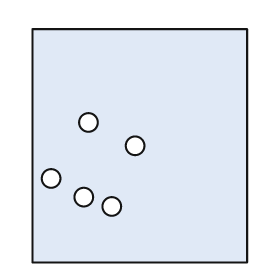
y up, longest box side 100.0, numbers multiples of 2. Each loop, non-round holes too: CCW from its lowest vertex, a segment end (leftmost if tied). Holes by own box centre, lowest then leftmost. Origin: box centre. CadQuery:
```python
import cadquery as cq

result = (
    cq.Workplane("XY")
    .moveTo(-46.0, -50.0)
    .lineTo(46.0, -50.0)
    .lineTo(46.0, 50.0)
    .lineTo(-46.0, 50.0)
    .close()
    .moveTo(-12.0, -26.0)
    .circle(4.0)
    .moveTo(-24.0, -22.0)
    .circle(4.0)
    .moveTo(-38.0, -14.0)
    .circle(4.0)
    .moveTo(-2.0, 0.0)
    .circle(4.0)
    .moveTo(-22.0, 10.0)
    .circle(4.0)
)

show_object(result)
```